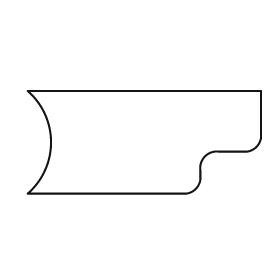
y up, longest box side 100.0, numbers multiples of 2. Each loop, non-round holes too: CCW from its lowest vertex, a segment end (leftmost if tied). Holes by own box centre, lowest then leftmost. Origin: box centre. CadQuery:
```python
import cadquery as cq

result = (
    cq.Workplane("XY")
    .moveTo(-50.0, -22.0)
    .lineTo(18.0, -22.0)
    .threePointArc((22.0, -20.0), (24.0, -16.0))
    .lineTo(24.0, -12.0)
    .threePointArc((26.0, -6.0), (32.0, -4.0))
    .lineTo(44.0, -4.0)
    .threePointArc((48.0, -2.0), (50.0, 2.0))
    .lineTo(50.0, 22.0)
    .lineTo(-50.0, 22.0)
    .threePointArc((-40.0, 0.0), (-50.0, -22.0))
    .close()
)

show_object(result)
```